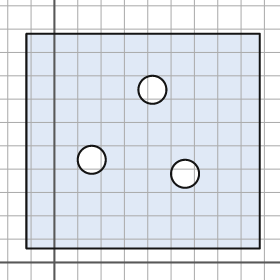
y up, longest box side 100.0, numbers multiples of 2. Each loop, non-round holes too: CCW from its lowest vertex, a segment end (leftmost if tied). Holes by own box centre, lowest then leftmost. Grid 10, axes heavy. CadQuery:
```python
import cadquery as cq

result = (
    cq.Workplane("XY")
    .moveTo(-12.0, 6.0)
    .lineTo(88.0, 6.0)
    .lineTo(88.0, 98.0)
    .lineTo(-12.0, 98.0)
    .close()
    .moveTo(56.0, 38.0)
    .circle(6.0)
    .moveTo(16.0, 44.0)
    .circle(6.0)
    .moveTo(42.0, 74.0)
    .circle(6.0)
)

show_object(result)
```